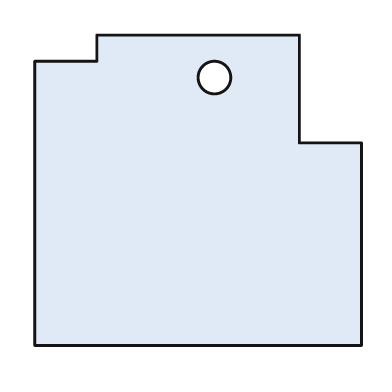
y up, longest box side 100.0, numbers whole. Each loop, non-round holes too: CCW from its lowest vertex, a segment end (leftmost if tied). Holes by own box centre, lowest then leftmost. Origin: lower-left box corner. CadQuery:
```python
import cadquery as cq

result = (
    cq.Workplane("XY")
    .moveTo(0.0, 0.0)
    .lineTo(100.0, 0.0)
    .lineTo(100.0, 62.0)
    .lineTo(81.0, 62.0)
    .lineTo(81.0, 95.0)
    .lineTo(19.0, 95.0)
    .lineTo(19.0, 87.0)
    .lineTo(0.0, 87.0)
    .close()
    .moveTo(55.0, 82.0)
    .circle(5.0)
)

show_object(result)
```